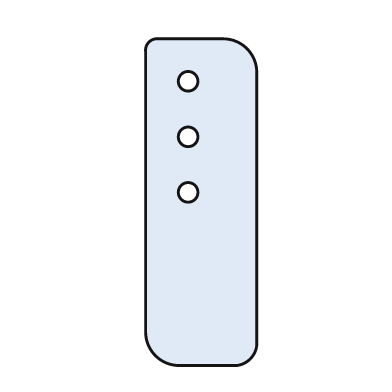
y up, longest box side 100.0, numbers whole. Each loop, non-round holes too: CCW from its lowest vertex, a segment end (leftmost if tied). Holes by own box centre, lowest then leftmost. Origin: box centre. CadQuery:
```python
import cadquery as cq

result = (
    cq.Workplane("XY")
    .moveTo(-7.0, -50.0)
    .lineTo(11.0, -50.0)
    .threePointArc((15.0, -48.0), (17.0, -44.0))
    .lineTo(17.0, 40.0)
    .threePointArc((14.0, 47.0), (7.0, 50.0))
    .lineTo(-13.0, 50.0)
    .threePointArc((-16.0, 49.0), (-17.0, 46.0))
    .lineTo(-17.0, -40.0)
    .threePointArc((-14.0, -47.0), (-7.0, -50.0))
    .close()
    .moveTo(-4.0, 3.0)
    .circle(3.0)
    .moveTo(-4.0, 20.0)
    .circle(3.0)
    .moveTo(-4.0, 37.0)
    .circle(3.0)
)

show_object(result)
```